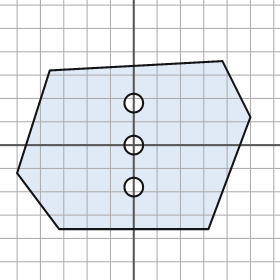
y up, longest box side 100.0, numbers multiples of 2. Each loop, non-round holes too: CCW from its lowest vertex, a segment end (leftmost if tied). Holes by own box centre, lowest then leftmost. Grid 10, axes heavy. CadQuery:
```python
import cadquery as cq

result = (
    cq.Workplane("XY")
    .moveTo(-32.0, -36.0)
    .lineTo(32.0, -36.0)
    .lineTo(50.0, 12.0)
    .lineTo(38.0, 36.0)
    .lineTo(-36.0, 32.0)
    .lineTo(-50.0, -12.0)
    .close()
    .moveTo(0.0, -18.0)
    .circle(4.0)
    .moveTo(0.0, 0.0)
    .circle(4.0)
    .moveTo(0.0, 18.0)
    .circle(4.0)
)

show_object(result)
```